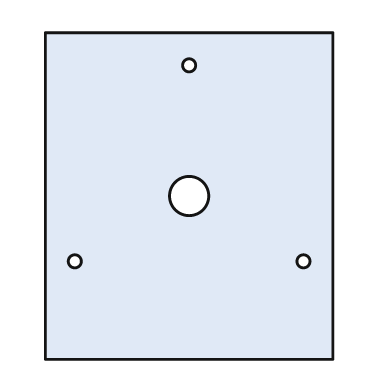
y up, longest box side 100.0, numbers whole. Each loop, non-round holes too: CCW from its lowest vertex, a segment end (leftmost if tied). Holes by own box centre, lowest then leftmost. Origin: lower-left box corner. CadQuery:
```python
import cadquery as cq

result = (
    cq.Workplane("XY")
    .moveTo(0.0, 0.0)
    .lineTo(88.0, 0.0)
    .lineTo(88.0, 100.0)
    .lineTo(0.0, 100.0)
    .close()
    .moveTo(9.0, 30.0)
    .circle(2.0)
    .moveTo(79.0, 30.0)
    .circle(2.0)
    .moveTo(44.0, 50.0)
    .circle(6.0)
    .moveTo(44.0, 90.0)
    .circle(2.0)
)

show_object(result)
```